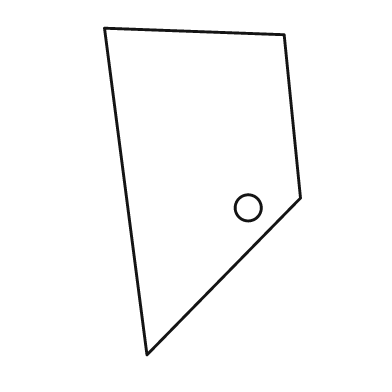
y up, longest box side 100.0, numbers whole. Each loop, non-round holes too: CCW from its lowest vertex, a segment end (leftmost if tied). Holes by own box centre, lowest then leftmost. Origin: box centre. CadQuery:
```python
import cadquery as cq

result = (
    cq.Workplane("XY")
    .moveTo(-17.0, -50.0)
    .lineTo(30.0, -2.0)
    .lineTo(25.0, 48.0)
    .lineTo(-30.0, 50.0)
    .close()
    .moveTo(14.0, -5.0)
    .circle(4.0)
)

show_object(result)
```